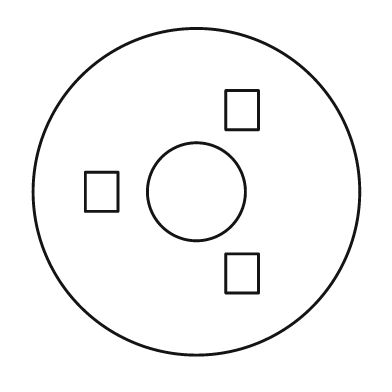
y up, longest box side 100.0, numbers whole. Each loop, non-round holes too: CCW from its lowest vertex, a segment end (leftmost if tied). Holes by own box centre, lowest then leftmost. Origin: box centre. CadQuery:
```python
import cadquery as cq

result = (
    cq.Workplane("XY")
    .moveTo(0.0, 0.0)
    .circle(50.0)
    .moveTo(9.0, -31.0)
    .lineTo(19.0, -31.0)
    .lineTo(19.0, -19.0)
    .lineTo(9.0, -19.0)
    .close()
    .moveTo(-34.0, -6.0)
    .lineTo(-24.0, -6.0)
    .lineTo(-24.0, 6.0)
    .lineTo(-34.0, 6.0)
    .close()
    .moveTo(0.0, 0.0)
    .circle(15.0)
    .moveTo(9.0, 19.0)
    .lineTo(19.0, 19.0)
    .lineTo(19.0, 31.0)
    .lineTo(9.0, 31.0)
    .close()
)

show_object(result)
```